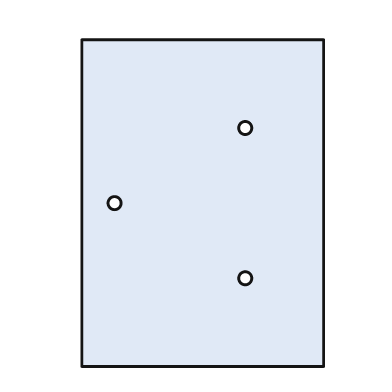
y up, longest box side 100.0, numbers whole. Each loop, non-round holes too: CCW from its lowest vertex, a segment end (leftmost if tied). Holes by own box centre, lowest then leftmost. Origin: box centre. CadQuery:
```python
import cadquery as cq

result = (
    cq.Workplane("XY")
    .moveTo(-37.0, -50.0)
    .lineTo(37.0, -50.0)
    .lineTo(37.0, 50.0)
    .lineTo(-37.0, 50.0)
    .close()
    .moveTo(13.0, -23.0)
    .circle(2.0)
    .moveTo(-27.0, 0.0)
    .circle(2.0)
    .moveTo(13.0, 23.0)
    .circle(2.0)
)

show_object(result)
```